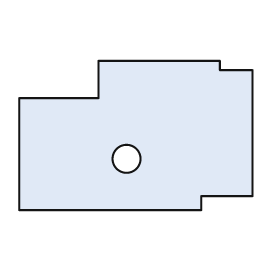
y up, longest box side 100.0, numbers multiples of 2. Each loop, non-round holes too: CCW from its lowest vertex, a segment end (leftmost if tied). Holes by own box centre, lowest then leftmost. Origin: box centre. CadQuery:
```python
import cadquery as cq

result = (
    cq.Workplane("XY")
    .moveTo(-50.0, -32.0)
    .lineTo(28.0, -32.0)
    .lineTo(28.0, -26.0)
    .lineTo(50.0, -26.0)
    .lineTo(50.0, 28.0)
    .lineTo(36.0, 28.0)
    .lineTo(36.0, 32.0)
    .lineTo(-16.0, 32.0)
    .lineTo(-16.0, 16.0)
    .lineTo(-50.0, 16.0)
    .close()
    .moveTo(-4.0, -10.0)
    .circle(6.0)
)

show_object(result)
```